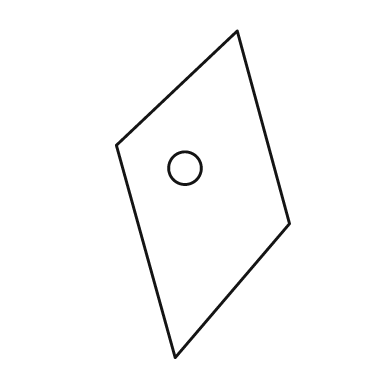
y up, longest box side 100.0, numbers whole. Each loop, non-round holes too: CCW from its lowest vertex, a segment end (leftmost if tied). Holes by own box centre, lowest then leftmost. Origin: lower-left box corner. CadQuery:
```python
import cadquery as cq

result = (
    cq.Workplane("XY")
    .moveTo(18.0, 0.0)
    .lineTo(53.0, 41.0)
    .lineTo(37.0, 100.0)
    .lineTo(0.0, 65.0)
    .close()
    .moveTo(21.0, 58.0)
    .circle(5.0)
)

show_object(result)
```